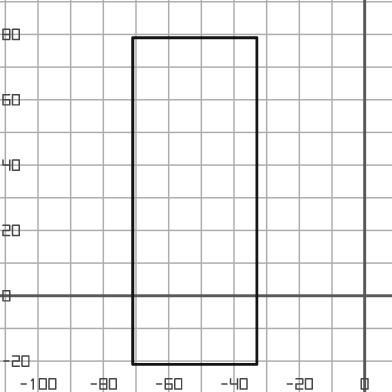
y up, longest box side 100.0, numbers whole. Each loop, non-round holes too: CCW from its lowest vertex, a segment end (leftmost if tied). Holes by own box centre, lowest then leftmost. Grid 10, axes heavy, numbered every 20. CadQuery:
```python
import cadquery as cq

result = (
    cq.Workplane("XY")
    .moveTo(-71.0, -21.0)
    .lineTo(-33.0, -21.0)
    .lineTo(-33.0, 79.0)
    .lineTo(-71.0, 79.0)
    .close()
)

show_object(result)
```